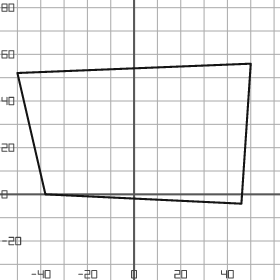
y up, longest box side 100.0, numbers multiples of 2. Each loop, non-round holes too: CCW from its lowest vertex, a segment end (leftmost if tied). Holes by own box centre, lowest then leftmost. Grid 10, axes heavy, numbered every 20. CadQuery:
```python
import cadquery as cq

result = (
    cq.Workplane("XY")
    .moveTo(46.0, -4.0)
    .lineTo(50.0, 56.0)
    .lineTo(-50.0, 52.0)
    .lineTo(-38.0, 0.0)
    .close()
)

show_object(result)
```